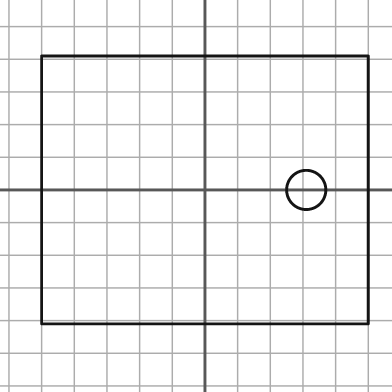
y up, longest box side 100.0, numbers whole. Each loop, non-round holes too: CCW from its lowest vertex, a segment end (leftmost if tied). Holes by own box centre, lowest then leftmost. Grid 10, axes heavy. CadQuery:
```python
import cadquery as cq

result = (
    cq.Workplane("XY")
    .moveTo(-50.0, -41.0)
    .lineTo(50.0, -41.0)
    .lineTo(50.0, 41.0)
    .lineTo(-50.0, 41.0)
    .close()
    .moveTo(31.0, 0.0)
    .circle(6.0)
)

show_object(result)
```